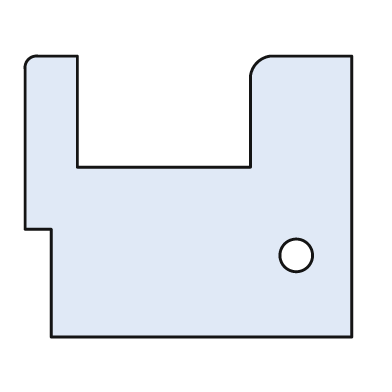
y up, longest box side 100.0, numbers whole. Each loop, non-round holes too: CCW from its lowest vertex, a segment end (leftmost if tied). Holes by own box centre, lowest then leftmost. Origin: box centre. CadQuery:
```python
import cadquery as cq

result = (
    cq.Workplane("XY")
    .moveTo(-42.0, -43.0)
    .lineTo(50.0, -43.0)
    .lineTo(50.0, 43.0)
    .lineTo(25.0, 43.0)
    .threePointArc((21.0, 41.0), (19.0, 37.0))
    .lineTo(19.0, 9.0)
    .lineTo(-34.0, 9.0)
    .lineTo(-34.0, 43.0)
    .lineTo(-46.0, 43.0)
    .threePointArc((-49.0, 42.0), (-50.0, 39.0))
    .lineTo(-50.0, -10.0)
    .lineTo(-42.0, -10.0)
    .close()
    .moveTo(33.0, -18.0)
    .circle(5.0)
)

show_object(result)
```